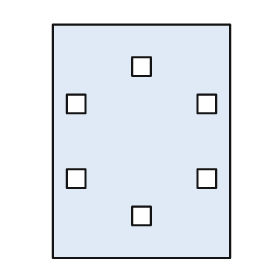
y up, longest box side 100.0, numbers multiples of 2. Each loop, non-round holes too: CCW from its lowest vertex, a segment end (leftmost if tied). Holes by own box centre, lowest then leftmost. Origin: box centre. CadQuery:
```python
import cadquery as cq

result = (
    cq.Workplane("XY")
    .moveTo(-38.0, -50.0)
    .lineTo(38.0, -50.0)
    .lineTo(38.0, 50.0)
    .lineTo(-38.0, 50.0)
    .close()
    .moveTo(-4.0, -36.0)
    .lineTo(4.0, -36.0)
    .lineTo(4.0, -28.0)
    .lineTo(-4.0, -28.0)
    .close()
    .moveTo(-32.0, -20.0)
    .lineTo(-24.0, -20.0)
    .lineTo(-24.0, -12.0)
    .lineTo(-32.0, -12.0)
    .close()
    .moveTo(24.0, -20.0)
    .lineTo(32.0, -20.0)
    .lineTo(32.0, -12.0)
    .lineTo(24.0, -12.0)
    .close()
    .moveTo(-32.0, 12.0)
    .lineTo(-24.0, 12.0)
    .lineTo(-24.0, 20.0)
    .lineTo(-32.0, 20.0)
    .close()
    .moveTo(24.0, 12.0)
    .lineTo(32.0, 12.0)
    .lineTo(32.0, 20.0)
    .lineTo(24.0, 20.0)
    .close()
    .moveTo(-4.0, 28.0)
    .lineTo(4.0, 28.0)
    .lineTo(4.0, 36.0)
    .lineTo(-4.0, 36.0)
    .close()
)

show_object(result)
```